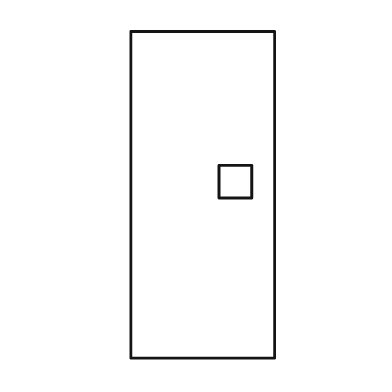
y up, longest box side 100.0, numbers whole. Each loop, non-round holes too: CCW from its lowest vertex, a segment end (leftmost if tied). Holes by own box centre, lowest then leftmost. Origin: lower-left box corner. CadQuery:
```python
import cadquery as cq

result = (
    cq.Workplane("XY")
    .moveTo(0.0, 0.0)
    .lineTo(44.0, 0.0)
    .lineTo(44.0, 100.0)
    .lineTo(0.0, 100.0)
    .close()
    .moveTo(27.0, 49.0)
    .lineTo(37.0, 49.0)
    .lineTo(37.0, 59.0)
    .lineTo(27.0, 59.0)
    .close()
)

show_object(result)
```